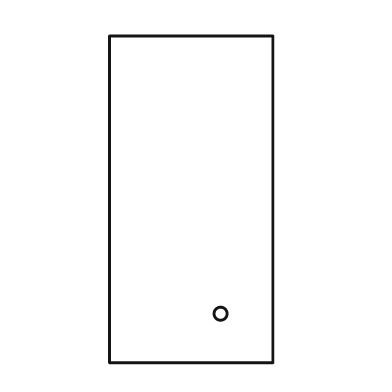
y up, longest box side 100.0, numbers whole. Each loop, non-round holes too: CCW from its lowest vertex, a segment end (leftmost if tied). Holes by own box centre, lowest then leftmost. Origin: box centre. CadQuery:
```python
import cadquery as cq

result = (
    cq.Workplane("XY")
    .moveTo(-25.0, -50.0)
    .lineTo(25.0, -50.0)
    .lineTo(25.0, 50.0)
    .lineTo(-25.0, 50.0)
    .close()
    .moveTo(9.0, -35.0)
    .circle(2.0)
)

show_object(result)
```